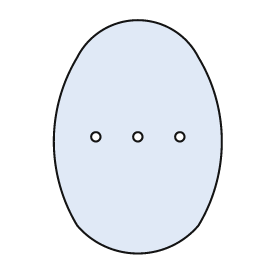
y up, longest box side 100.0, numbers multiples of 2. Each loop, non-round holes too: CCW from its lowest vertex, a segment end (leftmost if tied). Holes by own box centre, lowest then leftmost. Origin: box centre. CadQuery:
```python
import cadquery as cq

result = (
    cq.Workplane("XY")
    .moveTo(-26.0, -38.0)
    .threePointArc((0.0, -50.0), (26.0, -38.0))
    .threePointArc((36.0, -2.0), (26.0, 34.0))
    .threePointArc((0.0, 50.0), (-26.0, 34.0))
    .threePointArc((-36.0, -2.0), (-26.0, -38.0))
    .close()
    .moveTo(-18.0, 0.0)
    .circle(2.0)
    .moveTo(0.0, 0.0)
    .circle(2.0)
    .moveTo(18.0, 0.0)
    .circle(2.0)
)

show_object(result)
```